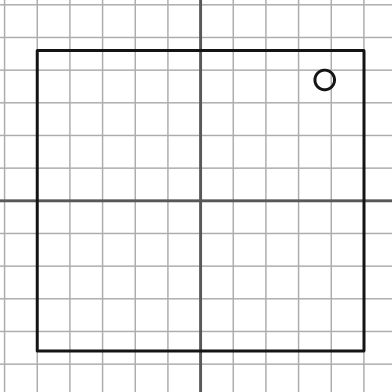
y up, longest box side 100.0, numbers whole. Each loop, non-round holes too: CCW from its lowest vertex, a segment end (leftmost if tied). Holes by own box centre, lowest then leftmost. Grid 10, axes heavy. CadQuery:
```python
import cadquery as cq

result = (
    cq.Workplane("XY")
    .moveTo(-50.0, -46.0)
    .lineTo(50.0, -46.0)
    .lineTo(50.0, 46.0)
    .lineTo(-50.0, 46.0)
    .close()
    .moveTo(38.0, 37.0)
    .circle(3.0)
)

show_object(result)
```